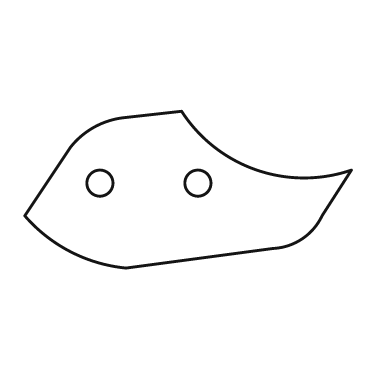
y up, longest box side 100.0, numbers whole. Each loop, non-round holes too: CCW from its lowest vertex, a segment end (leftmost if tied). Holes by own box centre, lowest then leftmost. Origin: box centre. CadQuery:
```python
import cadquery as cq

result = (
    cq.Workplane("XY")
    .moveTo(-19.0, -24.0)
    .lineTo(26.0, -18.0)
    .threePointArc((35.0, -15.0), (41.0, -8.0))
    .lineTo(50.0, 6.0)
    .threePointArc((21.0, 6.0), (-2.0, 24.0))
    .lineTo(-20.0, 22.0)
    .threePointArc((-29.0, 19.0), (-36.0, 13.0))
    .lineTo(-50.0, -8.0)
    .threePointArc((-36.0, -19.0), (-19.0, -24.0))
    .close()
    .moveTo(-27.0, 2.0)
    .circle(4.0)
    .moveTo(3.0, 2.0)
    .circle(4.0)
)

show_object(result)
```